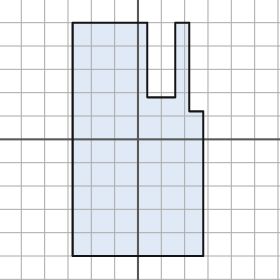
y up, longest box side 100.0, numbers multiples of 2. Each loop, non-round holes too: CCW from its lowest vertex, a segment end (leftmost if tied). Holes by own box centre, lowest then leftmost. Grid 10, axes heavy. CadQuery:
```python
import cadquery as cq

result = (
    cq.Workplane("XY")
    .moveTo(-28.0, -50.0)
    .lineTo(28.0, -50.0)
    .lineTo(28.0, 12.0)
    .lineTo(22.0, 12.0)
    .lineTo(22.0, 50.0)
    .lineTo(16.0, 50.0)
    .lineTo(16.0, 18.0)
    .lineTo(4.0, 18.0)
    .lineTo(4.0, 50.0)
    .lineTo(-28.0, 50.0)
    .close()
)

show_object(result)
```